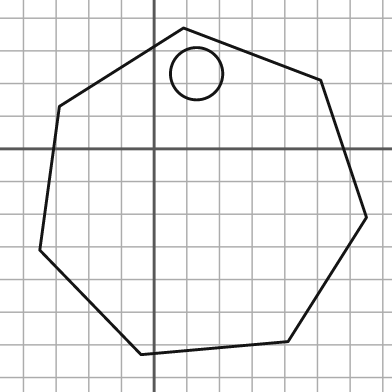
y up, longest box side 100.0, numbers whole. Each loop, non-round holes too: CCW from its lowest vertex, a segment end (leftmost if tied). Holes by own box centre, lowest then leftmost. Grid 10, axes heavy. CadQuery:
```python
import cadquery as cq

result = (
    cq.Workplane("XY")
    .moveTo(-4.0, -63.0)
    .lineTo(41.0, -59.0)
    .lineTo(65.0, -21.0)
    .lineTo(51.0, 21.0)
    .lineTo(9.0, 37.0)
    .lineTo(-29.0, 13.0)
    .lineTo(-35.0, -31.0)
    .close()
    .moveTo(13.0, 23.0)
    .circle(8.0)
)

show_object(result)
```